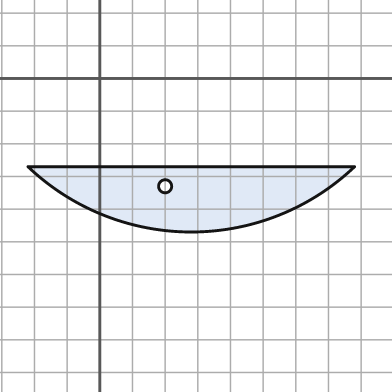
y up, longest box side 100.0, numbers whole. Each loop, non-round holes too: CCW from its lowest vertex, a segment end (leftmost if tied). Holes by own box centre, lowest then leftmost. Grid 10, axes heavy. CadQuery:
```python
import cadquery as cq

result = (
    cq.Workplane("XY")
    .moveTo(-22.0, -27.0)
    .threePointArc((28.0, -47.0), (78.0, -27.0))
    .close()
    .moveTo(20.0, -33.0)
    .circle(2.0)
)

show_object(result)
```